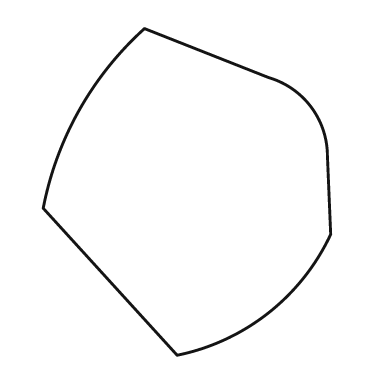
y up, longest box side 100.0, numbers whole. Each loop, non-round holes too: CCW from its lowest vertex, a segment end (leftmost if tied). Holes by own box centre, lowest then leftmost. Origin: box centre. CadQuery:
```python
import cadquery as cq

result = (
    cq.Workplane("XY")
    .moveTo(-3.0, -50.0)
    .threePointArc((25.0, -37.0), (44.0, -13.0))
    .lineTo(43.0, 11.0)
    .threePointArc((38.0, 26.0), (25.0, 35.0))
    .lineTo(-13.0, 50.0)
    .threePointArc((-33.0, 25.0), (-44.0, -5.0))
    .close()
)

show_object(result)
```